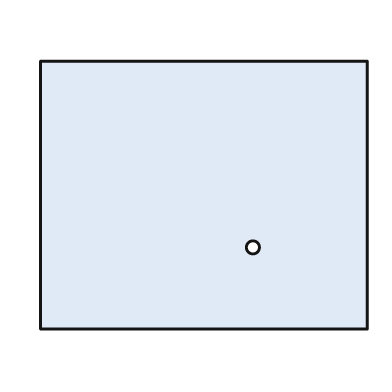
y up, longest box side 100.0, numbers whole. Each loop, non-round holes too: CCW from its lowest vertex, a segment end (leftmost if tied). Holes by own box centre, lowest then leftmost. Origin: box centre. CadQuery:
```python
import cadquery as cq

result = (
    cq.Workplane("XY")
    .moveTo(-50.0, -41.0)
    .lineTo(50.0, -41.0)
    .lineTo(50.0, 41.0)
    .lineTo(-50.0, 41.0)
    .close()
    .moveTo(15.0, -16.0)
    .circle(2.0)
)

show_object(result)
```